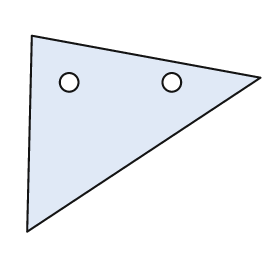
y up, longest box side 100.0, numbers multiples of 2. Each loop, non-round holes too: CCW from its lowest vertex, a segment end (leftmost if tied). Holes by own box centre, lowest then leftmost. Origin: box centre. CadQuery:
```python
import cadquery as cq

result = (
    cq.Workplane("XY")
    .moveTo(-50.0, -42.0)
    .lineTo(50.0, 24.0)
    .lineTo(-48.0, 42.0)
    .close()
    .moveTo(-32.0, 22.0)
    .circle(4.0)
    .moveTo(12.0, 22.0)
    .circle(4.0)
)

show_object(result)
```